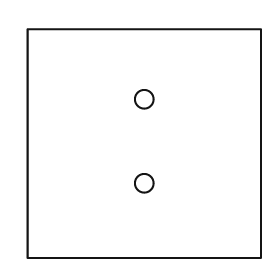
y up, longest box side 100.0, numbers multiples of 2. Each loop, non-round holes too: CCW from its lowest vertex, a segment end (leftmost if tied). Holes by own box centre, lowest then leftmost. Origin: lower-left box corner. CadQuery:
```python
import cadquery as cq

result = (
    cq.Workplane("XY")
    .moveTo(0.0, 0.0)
    .lineTo(100.0, 0.0)
    .lineTo(100.0, 98.0)
    .lineTo(0.0, 98.0)
    .close()
    .moveTo(50.0, 32.0)
    .circle(4.0)
    .moveTo(50.0, 68.0)
    .circle(4.0)
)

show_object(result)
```